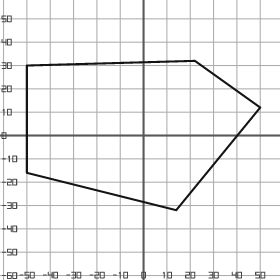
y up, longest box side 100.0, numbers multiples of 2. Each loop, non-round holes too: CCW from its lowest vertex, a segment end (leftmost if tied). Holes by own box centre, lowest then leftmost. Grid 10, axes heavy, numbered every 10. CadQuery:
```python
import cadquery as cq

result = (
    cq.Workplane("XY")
    .moveTo(14.0, -32.0)
    .lineTo(50.0, 12.0)
    .lineTo(22.0, 32.0)
    .lineTo(-50.0, 30.0)
    .lineTo(-50.0, -16.0)
    .close()
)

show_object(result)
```